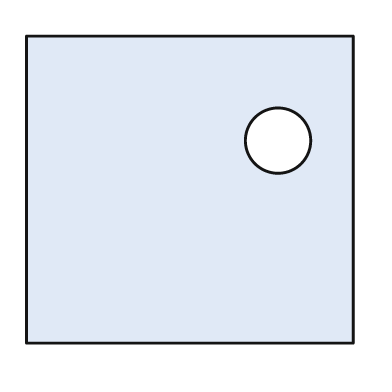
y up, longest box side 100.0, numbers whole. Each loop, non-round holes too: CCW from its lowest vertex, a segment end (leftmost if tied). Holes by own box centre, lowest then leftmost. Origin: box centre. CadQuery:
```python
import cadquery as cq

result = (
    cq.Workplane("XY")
    .moveTo(-50.0, -47.0)
    .lineTo(50.0, -47.0)
    .lineTo(50.0, 47.0)
    .lineTo(-50.0, 47.0)
    .close()
    .moveTo(27.0, 15.0)
    .circle(10.0)
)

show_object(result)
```